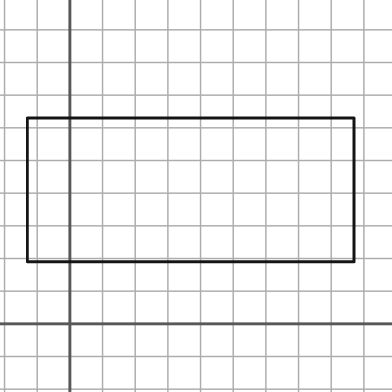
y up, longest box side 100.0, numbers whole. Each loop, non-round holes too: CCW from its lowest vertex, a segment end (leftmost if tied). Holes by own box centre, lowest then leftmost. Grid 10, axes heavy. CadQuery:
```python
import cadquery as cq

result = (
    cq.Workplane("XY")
    .moveTo(-13.0, 19.0)
    .lineTo(87.0, 19.0)
    .lineTo(87.0, 63.0)
    .lineTo(-13.0, 63.0)
    .close()
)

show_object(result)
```